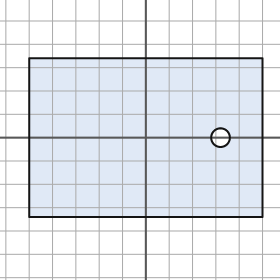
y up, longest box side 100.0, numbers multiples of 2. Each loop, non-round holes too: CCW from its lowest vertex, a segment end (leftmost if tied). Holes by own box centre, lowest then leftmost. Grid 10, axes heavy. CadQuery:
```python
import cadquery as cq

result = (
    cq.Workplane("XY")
    .moveTo(-50.0, -34.0)
    .lineTo(50.0, -34.0)
    .lineTo(50.0, 34.0)
    .lineTo(-50.0, 34.0)
    .close()
    .moveTo(32.0, 0.0)
    .circle(4.0)
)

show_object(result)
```